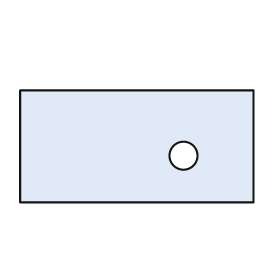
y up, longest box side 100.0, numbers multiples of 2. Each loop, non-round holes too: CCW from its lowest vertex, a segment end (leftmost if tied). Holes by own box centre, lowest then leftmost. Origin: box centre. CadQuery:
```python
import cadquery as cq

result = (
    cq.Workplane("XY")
    .moveTo(-50.0, -24.0)
    .lineTo(50.0, -24.0)
    .lineTo(50.0, 24.0)
    .lineTo(-50.0, 24.0)
    .close()
    .moveTo(20.0, -4.0)
    .circle(6.0)
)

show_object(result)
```